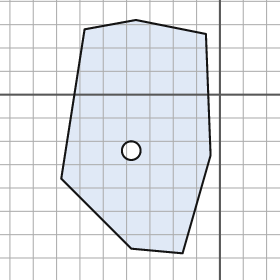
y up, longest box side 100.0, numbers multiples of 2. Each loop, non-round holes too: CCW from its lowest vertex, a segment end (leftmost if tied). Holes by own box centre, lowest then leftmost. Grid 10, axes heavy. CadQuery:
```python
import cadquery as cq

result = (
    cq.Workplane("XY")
    .moveTo(-16.0, -68.0)
    .lineTo(-4.0, -26.0)
    .lineTo(-6.0, 26.0)
    .lineTo(-36.0, 32.0)
    .lineTo(-58.0, 28.0)
    .lineTo(-68.0, -36.0)
    .lineTo(-38.0, -66.0)
    .close()
    .moveTo(-38.0, -24.0)
    .circle(4.0)
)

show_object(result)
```